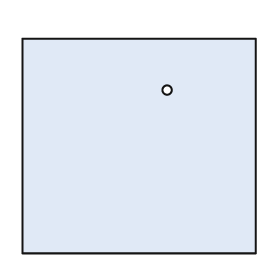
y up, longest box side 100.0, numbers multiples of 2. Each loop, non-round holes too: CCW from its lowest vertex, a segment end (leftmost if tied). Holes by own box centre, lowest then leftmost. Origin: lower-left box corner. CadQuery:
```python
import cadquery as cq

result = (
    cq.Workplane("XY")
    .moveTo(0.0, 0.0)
    .lineTo(100.0, 0.0)
    .lineTo(100.0, 92.0)
    .lineTo(0.0, 92.0)
    .close()
    .moveTo(62.0, 70.0)
    .circle(2.0)
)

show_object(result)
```